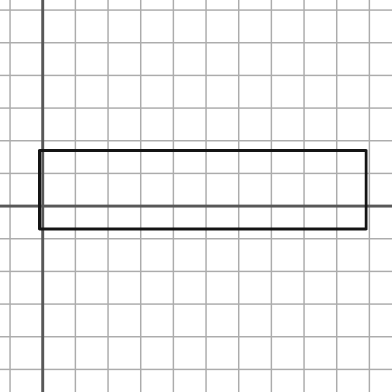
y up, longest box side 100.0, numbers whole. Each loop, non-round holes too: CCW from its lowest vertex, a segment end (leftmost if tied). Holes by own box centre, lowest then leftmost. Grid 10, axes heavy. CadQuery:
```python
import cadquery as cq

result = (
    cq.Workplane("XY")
    .moveTo(-1.0, -7.0)
    .lineTo(99.0, -7.0)
    .lineTo(99.0, 17.0)
    .lineTo(-1.0, 17.0)
    .close()
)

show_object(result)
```